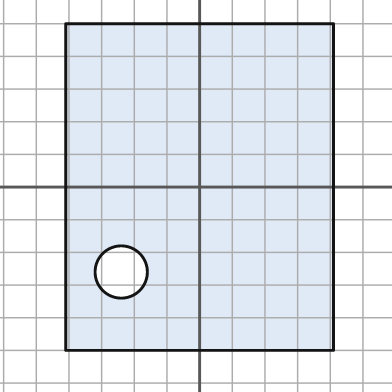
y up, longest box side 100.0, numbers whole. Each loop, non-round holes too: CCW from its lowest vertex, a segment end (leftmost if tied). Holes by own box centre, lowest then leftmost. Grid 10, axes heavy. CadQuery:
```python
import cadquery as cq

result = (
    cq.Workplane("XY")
    .moveTo(-41.0, -50.0)
    .lineTo(41.0, -50.0)
    .lineTo(41.0, 50.0)
    .lineTo(-41.0, 50.0)
    .close()
    .moveTo(-24.0, -26.0)
    .circle(8.0)
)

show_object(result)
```